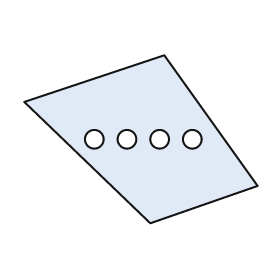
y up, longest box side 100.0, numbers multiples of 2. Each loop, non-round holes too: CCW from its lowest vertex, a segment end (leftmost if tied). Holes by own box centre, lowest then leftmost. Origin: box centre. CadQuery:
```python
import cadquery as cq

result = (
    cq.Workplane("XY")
    .moveTo(4.0, -36.0)
    .lineTo(50.0, -20.0)
    .lineTo(10.0, 36.0)
    .lineTo(-50.0, 16.0)
    .close()
    .moveTo(-20.0, 0.0)
    .circle(4.0)
    .moveTo(-6.0, 0.0)
    .circle(4.0)
    .moveTo(8.0, 0.0)
    .circle(4.0)
    .moveTo(22.0, 0.0)
    .circle(4.0)
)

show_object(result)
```